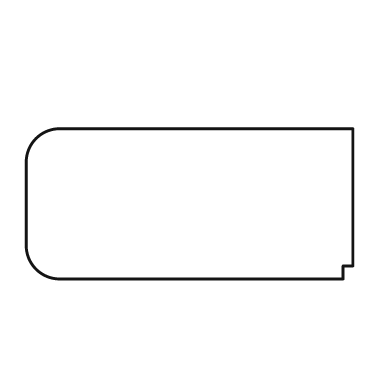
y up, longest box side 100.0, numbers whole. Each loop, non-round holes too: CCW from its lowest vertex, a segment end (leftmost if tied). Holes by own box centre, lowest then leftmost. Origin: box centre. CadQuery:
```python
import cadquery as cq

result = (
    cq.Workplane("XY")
    .moveTo(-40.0, -23.0)
    .lineTo(47.0, -23.0)
    .lineTo(47.0, -19.0)
    .lineTo(50.0, -19.0)
    .lineTo(50.0, 23.0)
    .lineTo(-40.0, 23.0)
    .threePointArc((-47.0, 20.0), (-50.0, 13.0))
    .lineTo(-50.0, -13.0)
    .threePointArc((-47.0, -20.0), (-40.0, -23.0))
    .close()
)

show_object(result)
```